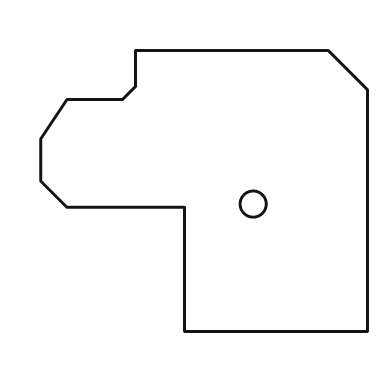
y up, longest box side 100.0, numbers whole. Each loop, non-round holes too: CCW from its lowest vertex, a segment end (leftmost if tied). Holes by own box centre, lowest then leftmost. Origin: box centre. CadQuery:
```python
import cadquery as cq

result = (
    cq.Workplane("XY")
    .moveTo(-6.0, -43.0)
    .lineTo(50.0, -43.0)
    .lineTo(50.0, 31.0)
    .lineTo(38.0, 43.0)
    .lineTo(-21.0, 43.0)
    .lineTo(-21.0, 32.0)
    .lineTo(-25.0, 28.0)
    .lineTo(-42.0, 28.0)
    .lineTo(-50.0, 16.0)
    .lineTo(-50.0, 3.0)
    .lineTo(-42.0, -5.0)
    .lineTo(-6.0, -5.0)
    .close()
    .moveTo(15.0, -4.0)
    .circle(4.0)
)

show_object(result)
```